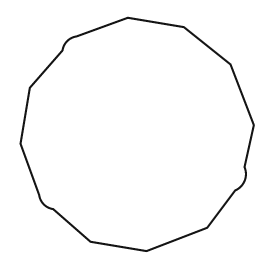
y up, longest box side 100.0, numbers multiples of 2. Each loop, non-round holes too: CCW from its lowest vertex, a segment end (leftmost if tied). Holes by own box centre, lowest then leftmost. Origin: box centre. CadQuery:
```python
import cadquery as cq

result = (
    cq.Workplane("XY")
    .moveTo(4.0, -50.0)
    .lineTo(30.0, -40.0)
    .lineTo(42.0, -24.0)
    .threePointArc((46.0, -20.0), (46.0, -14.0))
    .lineTo(50.0, 4.0)
    .lineTo(40.0, 30.0)
    .lineTo(20.0, 46.0)
    .lineTo(-4.0, 50.0)
    .lineTo(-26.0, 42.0)
    .threePointArc((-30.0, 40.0), (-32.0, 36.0))
    .lineTo(-46.0, 20.0)
    .lineTo(-50.0, -4.0)
    .lineTo(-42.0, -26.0)
    .threePointArc((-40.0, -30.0), (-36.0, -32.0))
    .lineTo(-20.0, -46.0)
    .close()
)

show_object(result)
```